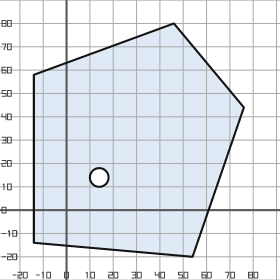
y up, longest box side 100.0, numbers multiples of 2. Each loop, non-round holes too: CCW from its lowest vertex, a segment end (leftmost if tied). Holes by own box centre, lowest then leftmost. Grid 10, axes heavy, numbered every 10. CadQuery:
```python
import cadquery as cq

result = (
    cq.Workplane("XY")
    .moveTo(54.0, -20.0)
    .lineTo(76.0, 44.0)
    .lineTo(46.0, 80.0)
    .lineTo(-14.0, 58.0)
    .lineTo(-14.0, -14.0)
    .close()
    .moveTo(14.0, 14.0)
    .circle(4.0)
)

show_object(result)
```